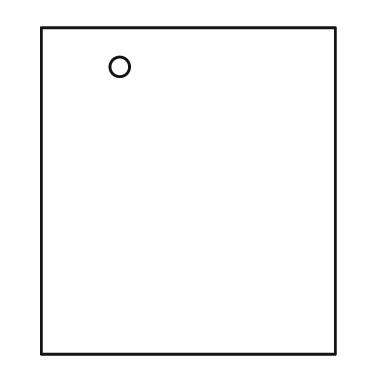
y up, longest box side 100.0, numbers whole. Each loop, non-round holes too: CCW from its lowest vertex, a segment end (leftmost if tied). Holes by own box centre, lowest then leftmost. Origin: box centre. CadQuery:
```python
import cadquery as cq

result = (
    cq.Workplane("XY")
    .moveTo(-45.0, -50.0)
    .lineTo(45.0, -50.0)
    .lineTo(45.0, 50.0)
    .lineTo(-45.0, 50.0)
    .close()
    .moveTo(-21.0, 38.0)
    .circle(3.0)
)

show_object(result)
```